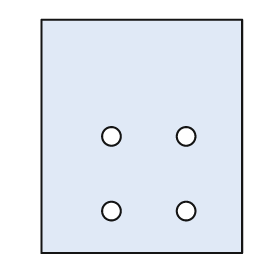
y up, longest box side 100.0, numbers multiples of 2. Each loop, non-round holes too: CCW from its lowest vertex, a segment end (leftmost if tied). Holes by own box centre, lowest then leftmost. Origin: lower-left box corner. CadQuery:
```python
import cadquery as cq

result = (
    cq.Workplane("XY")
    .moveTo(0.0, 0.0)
    .lineTo(86.0, 0.0)
    .lineTo(86.0, 100.0)
    .lineTo(0.0, 100.0)
    .close()
    .moveTo(30.0, 18.0)
    .circle(4.0)
    .moveTo(62.0, 18.0)
    .circle(4.0)
    .moveTo(30.0, 50.0)
    .circle(4.0)
    .moveTo(62.0, 50.0)
    .circle(4.0)
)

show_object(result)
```